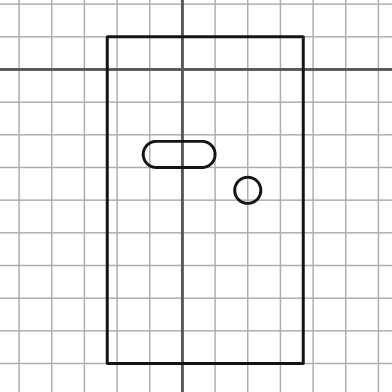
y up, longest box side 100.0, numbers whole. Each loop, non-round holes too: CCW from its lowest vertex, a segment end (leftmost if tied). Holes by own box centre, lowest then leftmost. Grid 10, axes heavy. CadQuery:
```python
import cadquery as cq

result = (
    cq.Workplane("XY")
    .moveTo(-23.0, -90.0)
    .lineTo(37.0, -90.0)
    .lineTo(37.0, 10.0)
    .lineTo(-23.0, 10.0)
    .close()
    .moveTo(20.0, -37.0)
    .circle(4.0)
    .moveTo(-8.0, -30.0)
    .lineTo(6.0, -30.0)
    .threePointArc((10.0, -26.0), (6.0, -22.0))
    .lineTo(-8.0, -22.0)
    .threePointArc((-12.0, -26.0), (-8.0, -30.0))
    .close()
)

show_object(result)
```